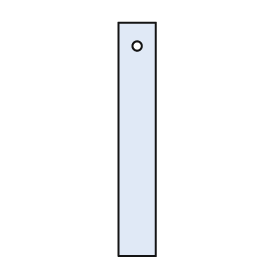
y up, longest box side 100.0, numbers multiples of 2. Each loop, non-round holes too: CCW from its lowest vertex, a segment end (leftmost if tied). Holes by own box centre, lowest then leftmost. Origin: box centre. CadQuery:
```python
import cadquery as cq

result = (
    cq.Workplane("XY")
    .moveTo(-8.0, -50.0)
    .lineTo(8.0, -50.0)
    .lineTo(8.0, 50.0)
    .lineTo(-8.0, 50.0)
    .close()
    .moveTo(0.0, 40.0)
    .circle(2.0)
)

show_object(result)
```